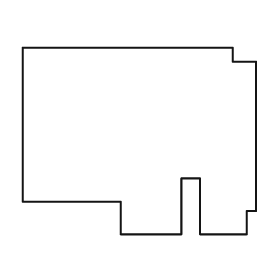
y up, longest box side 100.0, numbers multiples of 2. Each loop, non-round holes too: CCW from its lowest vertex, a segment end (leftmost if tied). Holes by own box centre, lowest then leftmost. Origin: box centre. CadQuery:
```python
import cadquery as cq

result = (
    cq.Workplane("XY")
    .moveTo(-8.0, -40.0)
    .lineTo(18.0, -40.0)
    .lineTo(18.0, -16.0)
    .lineTo(26.0, -16.0)
    .lineTo(26.0, -40.0)
    .lineTo(46.0, -40.0)
    .lineTo(46.0, -30.0)
    .lineTo(50.0, -30.0)
    .lineTo(50.0, 34.0)
    .lineTo(40.0, 34.0)
    .lineTo(40.0, 40.0)
    .lineTo(-50.0, 40.0)
    .lineTo(-50.0, -26.0)
    .lineTo(-8.0, -26.0)
    .close()
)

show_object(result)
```